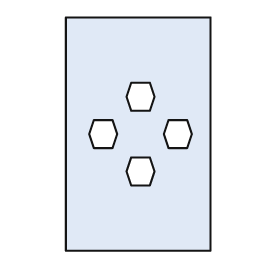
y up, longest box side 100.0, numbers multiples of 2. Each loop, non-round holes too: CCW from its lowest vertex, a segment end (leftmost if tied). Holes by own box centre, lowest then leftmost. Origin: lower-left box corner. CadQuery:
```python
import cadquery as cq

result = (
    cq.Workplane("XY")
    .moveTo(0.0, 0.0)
    .lineTo(62.0, 0.0)
    .lineTo(62.0, 100.0)
    .lineTo(0.0, 100.0)
    .close()
    .moveTo(28.0, 28.0)
    .lineTo(36.0, 28.0)
    .lineTo(38.0, 34.0)
    .lineTo(36.0, 40.0)
    .lineTo(28.0, 40.0)
    .lineTo(26.0, 34.0)
    .close()
    .moveTo(12.0, 44.0)
    .lineTo(20.0, 44.0)
    .lineTo(22.0, 50.0)
    .lineTo(20.0, 56.0)
    .lineTo(12.0, 56.0)
    .lineTo(10.0, 50.0)
    .close()
    .moveTo(44.0, 44.0)
    .lineTo(52.0, 44.0)
    .lineTo(54.0, 50.0)
    .lineTo(52.0, 56.0)
    .lineTo(44.0, 56.0)
    .lineTo(42.0, 50.0)
    .close()
    .moveTo(28.0, 60.0)
    .lineTo(36.0, 60.0)
    .lineTo(38.0, 66.0)
    .lineTo(36.0, 72.0)
    .lineTo(28.0, 72.0)
    .lineTo(26.0, 66.0)
    .close()
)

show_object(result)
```